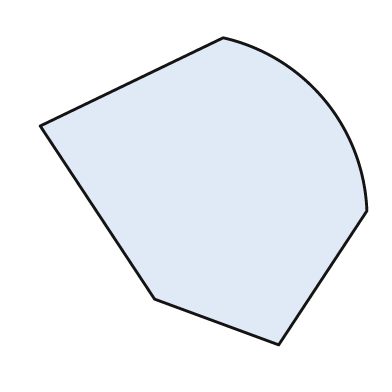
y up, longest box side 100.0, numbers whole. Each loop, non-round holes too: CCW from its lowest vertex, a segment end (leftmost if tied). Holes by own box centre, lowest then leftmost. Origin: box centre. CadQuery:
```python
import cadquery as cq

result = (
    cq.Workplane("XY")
    .moveTo(23.0, -47.0)
    .lineTo(50.0, -6.0)
    .threePointArc((37.0, 28.0), (6.0, 47.0))
    .lineTo(-50.0, 20.0)
    .lineTo(-15.0, -33.0)
    .close()
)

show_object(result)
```